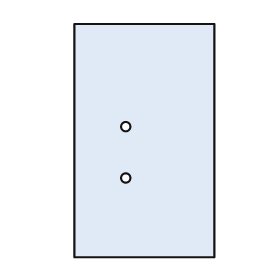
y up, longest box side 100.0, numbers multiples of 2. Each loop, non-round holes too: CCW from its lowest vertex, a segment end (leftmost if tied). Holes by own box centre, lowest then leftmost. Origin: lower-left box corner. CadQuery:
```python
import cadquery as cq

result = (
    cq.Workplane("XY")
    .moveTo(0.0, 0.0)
    .lineTo(60.0, 0.0)
    .lineTo(60.0, 100.0)
    .lineTo(0.0, 100.0)
    .close()
    .moveTo(22.0, 34.0)
    .circle(2.0)
    .moveTo(22.0, 56.0)
    .circle(2.0)
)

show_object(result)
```